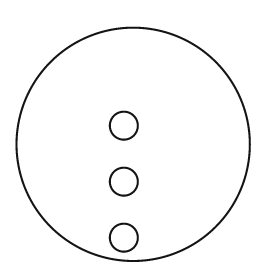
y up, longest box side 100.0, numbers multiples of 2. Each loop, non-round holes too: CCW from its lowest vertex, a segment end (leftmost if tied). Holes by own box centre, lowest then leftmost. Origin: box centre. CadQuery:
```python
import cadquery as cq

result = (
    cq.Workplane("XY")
    .moveTo(0.0, 0.0)
    .circle(50.0)
    .moveTo(-4.0, -40.0)
    .circle(6.0)
    .moveTo(-4.0, -16.0)
    .circle(6.0)
    .moveTo(-4.0, 8.0)
    .circle(6.0)
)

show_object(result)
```